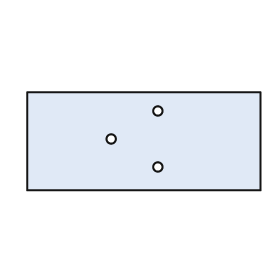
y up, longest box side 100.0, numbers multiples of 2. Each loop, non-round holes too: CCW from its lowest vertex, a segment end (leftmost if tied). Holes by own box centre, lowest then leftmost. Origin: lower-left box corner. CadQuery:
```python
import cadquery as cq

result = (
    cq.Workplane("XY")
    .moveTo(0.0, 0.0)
    .lineTo(100.0, 0.0)
    .lineTo(100.0, 42.0)
    .lineTo(0.0, 42.0)
    .close()
    .moveTo(56.0, 10.0)
    .circle(2.0)
    .moveTo(36.0, 22.0)
    .circle(2.0)
    .moveTo(56.0, 34.0)
    .circle(2.0)
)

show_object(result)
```